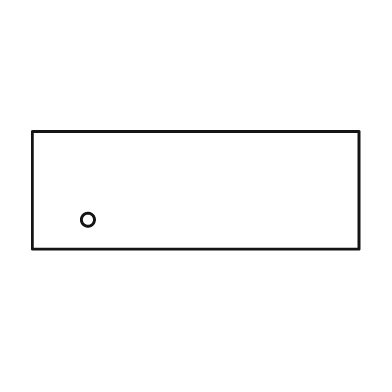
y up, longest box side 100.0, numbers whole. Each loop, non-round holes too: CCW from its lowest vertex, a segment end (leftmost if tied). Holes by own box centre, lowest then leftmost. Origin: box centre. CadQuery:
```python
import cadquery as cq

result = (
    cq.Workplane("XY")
    .moveTo(-50.0, -18.0)
    .lineTo(50.0, -18.0)
    .lineTo(50.0, 18.0)
    .lineTo(-50.0, 18.0)
    .close()
    .moveTo(-33.0, -9.0)
    .circle(2.0)
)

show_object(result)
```